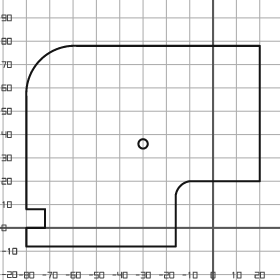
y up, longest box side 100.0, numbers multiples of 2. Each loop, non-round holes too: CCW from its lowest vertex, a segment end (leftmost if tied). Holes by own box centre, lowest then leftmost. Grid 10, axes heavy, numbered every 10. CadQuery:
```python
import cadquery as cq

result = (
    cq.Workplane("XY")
    .moveTo(-80.0, -8.0)
    .lineTo(-16.0, -8.0)
    .lineTo(-16.0, 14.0)
    .threePointArc((-14.0, 18.0), (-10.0, 20.0))
    .lineTo(20.0, 20.0)
    .lineTo(20.0, 78.0)
    .lineTo(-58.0, 78.0)
    .threePointArc((-74.0, 72.0), (-80.0, 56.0))
    .lineTo(-80.0, 8.0)
    .lineTo(-72.0, 8.0)
    .lineTo(-72.0, 0.0)
    .lineTo(-80.0, 0.0)
    .close()
    .moveTo(-30.0, 36.0)
    .circle(2.0)
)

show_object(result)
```